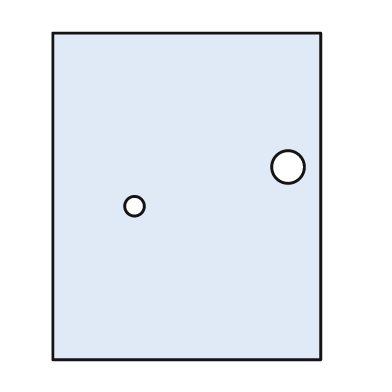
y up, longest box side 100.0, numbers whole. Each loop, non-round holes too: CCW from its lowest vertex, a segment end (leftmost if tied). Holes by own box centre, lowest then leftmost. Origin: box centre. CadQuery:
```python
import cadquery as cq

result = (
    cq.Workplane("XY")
    .moveTo(-41.0, -50.0)
    .lineTo(41.0, -50.0)
    .lineTo(41.0, 50.0)
    .lineTo(-41.0, 50.0)
    .close()
    .moveTo(-16.0, -3.0)
    .circle(3.0)
    .moveTo(31.0, 9.0)
    .circle(5.0)
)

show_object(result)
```